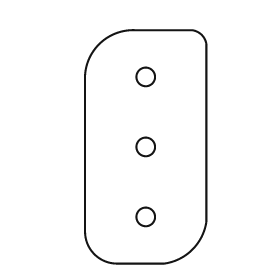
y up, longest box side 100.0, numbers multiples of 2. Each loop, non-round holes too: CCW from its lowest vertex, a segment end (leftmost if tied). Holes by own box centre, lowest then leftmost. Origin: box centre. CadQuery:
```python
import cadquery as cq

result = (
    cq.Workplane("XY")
    .moveTo(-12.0, -50.0)
    .lineTo(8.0, -50.0)
    .threePointArc((20.0, -44.0), (26.0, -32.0))
    .lineTo(26.0, 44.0)
    .threePointArc((24.0, 48.0), (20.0, 50.0))
    .lineTo(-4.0, 50.0)
    .threePointArc((-20.0, 44.0), (-26.0, 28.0))
    .lineTo(-26.0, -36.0)
    .threePointArc((-22.0, -46.0), (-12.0, -50.0))
    .close()
    .moveTo(0.0, -30.0)
    .circle(4.0)
    .moveTo(0.0, 0.0)
    .circle(4.0)
    .moveTo(0.0, 30.0)
    .circle(4.0)
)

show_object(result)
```